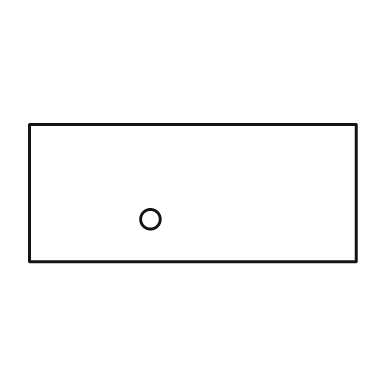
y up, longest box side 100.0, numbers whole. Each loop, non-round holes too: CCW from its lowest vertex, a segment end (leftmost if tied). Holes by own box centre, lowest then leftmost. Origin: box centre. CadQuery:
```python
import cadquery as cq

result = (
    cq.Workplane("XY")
    .moveTo(-50.0, -21.0)
    .lineTo(50.0, -21.0)
    .lineTo(50.0, 21.0)
    .lineTo(-50.0, 21.0)
    .close()
    .moveTo(-13.0, -8.0)
    .circle(3.0)
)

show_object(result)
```